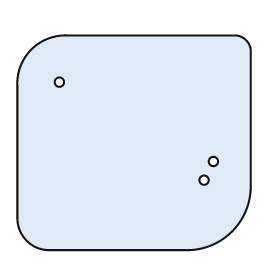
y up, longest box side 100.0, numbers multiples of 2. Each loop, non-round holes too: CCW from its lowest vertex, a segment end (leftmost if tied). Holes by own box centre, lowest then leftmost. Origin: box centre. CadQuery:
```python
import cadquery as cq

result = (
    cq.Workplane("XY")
    .moveTo(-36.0, -46.0)
    .lineTo(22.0, -46.0)
    .threePointArc((42.0, -38.0), (50.0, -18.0))
    .lineTo(50.0, 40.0)
    .threePointArc((48.0, 44.0), (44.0, 46.0))
    .lineTo(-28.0, 46.0)
    .threePointArc((-44.0, 40.0), (-50.0, 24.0))
    .lineTo(-50.0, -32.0)
    .threePointArc((-46.0, -42.0), (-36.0, -46.0))
    .close()
    .moveTo(30.0, -16.0)
    .circle(2.0)
    .moveTo(34.0, -8.0)
    .circle(2.0)
    .moveTo(-32.0, 26.0)
    .circle(2.0)
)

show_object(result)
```